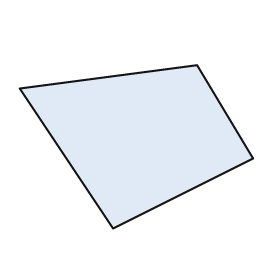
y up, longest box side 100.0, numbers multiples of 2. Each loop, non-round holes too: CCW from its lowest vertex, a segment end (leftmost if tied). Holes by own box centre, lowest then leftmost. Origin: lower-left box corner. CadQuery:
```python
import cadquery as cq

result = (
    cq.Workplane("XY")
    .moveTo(40.0, 0.0)
    .lineTo(100.0, 30.0)
    .lineTo(76.0, 70.0)
    .lineTo(0.0, 60.0)
    .close()
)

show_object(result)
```